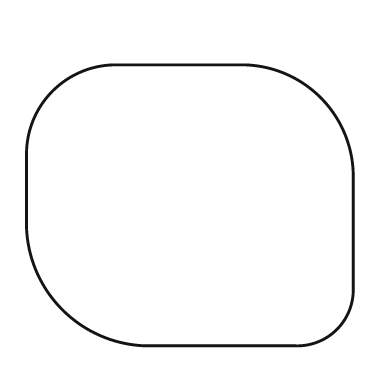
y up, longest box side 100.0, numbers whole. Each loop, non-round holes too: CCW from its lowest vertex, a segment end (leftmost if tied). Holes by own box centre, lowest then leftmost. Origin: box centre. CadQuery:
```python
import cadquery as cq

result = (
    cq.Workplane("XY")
    .moveTo(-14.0, -43.0)
    .lineTo(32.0, -43.0)
    .threePointArc((45.0, -38.0), (50.0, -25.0))
    .lineTo(50.0, 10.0)
    .threePointArc((40.0, 33.0), (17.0, 43.0))
    .lineTo(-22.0, 43.0)
    .threePointArc((-42.0, 35.0), (-50.0, 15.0))
    .lineTo(-50.0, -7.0)
    .threePointArc((-39.0, -32.0), (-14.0, -43.0))
    .close()
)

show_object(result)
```